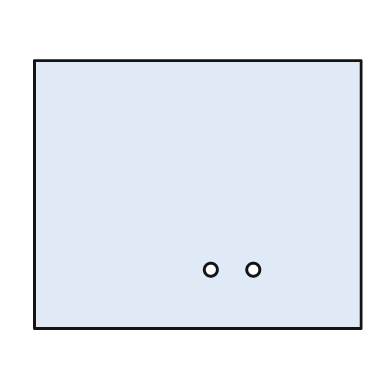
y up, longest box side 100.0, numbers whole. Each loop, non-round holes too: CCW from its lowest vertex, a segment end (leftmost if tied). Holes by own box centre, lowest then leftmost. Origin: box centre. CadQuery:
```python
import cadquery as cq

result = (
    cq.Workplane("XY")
    .moveTo(-50.0, -41.0)
    .lineTo(50.0, -41.0)
    .lineTo(50.0, 41.0)
    .lineTo(-50.0, 41.0)
    .close()
    .moveTo(4.0, -23.0)
    .circle(2.0)
    .moveTo(17.0, -23.0)
    .circle(2.0)
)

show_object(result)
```